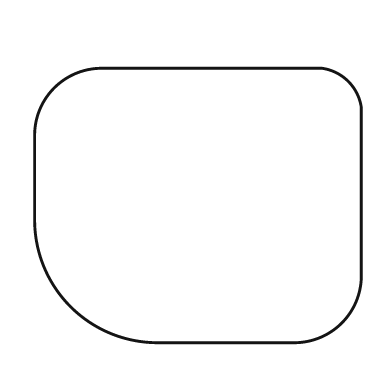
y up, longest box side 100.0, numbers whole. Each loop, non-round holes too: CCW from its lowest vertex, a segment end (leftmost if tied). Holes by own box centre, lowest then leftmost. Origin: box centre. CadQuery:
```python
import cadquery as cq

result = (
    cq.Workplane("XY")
    .moveTo(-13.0, -42.0)
    .lineTo(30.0, -42.0)
    .threePointArc((44.0, -36.0), (50.0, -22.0))
    .lineTo(50.0, 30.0)
    .threePointArc((46.0, 38.0), (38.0, 42.0))
    .lineTo(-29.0, 42.0)
    .threePointArc((-44.0, 36.0), (-50.0, 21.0))
    .lineTo(-50.0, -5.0)
    .threePointArc((-39.0, -31.0), (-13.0, -42.0))
    .close()
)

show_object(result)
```